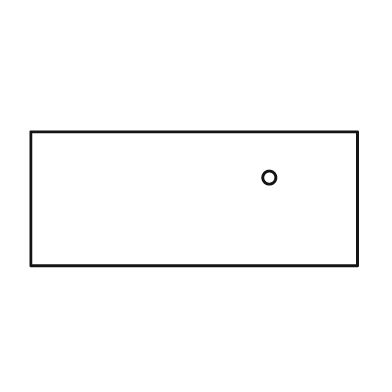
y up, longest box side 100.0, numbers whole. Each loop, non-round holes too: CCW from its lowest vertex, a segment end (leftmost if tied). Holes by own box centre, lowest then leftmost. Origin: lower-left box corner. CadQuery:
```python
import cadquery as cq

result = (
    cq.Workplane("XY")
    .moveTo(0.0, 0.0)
    .lineTo(100.0, 0.0)
    .lineTo(100.0, 41.0)
    .lineTo(0.0, 41.0)
    .close()
    .moveTo(73.0, 27.0)
    .circle(2.0)
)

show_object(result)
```